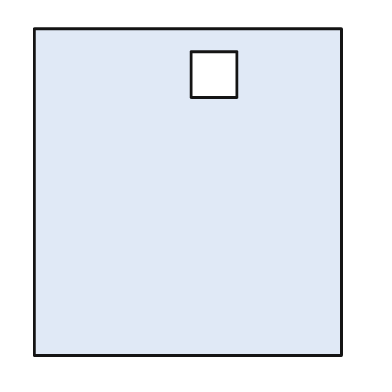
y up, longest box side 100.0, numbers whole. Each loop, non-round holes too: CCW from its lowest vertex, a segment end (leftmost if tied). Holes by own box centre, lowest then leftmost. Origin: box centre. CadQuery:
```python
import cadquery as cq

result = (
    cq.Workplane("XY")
    .moveTo(-47.0, -50.0)
    .lineTo(47.0, -50.0)
    .lineTo(47.0, 50.0)
    .lineTo(-47.0, 50.0)
    .close()
    .moveTo(1.0, 29.0)
    .lineTo(15.0, 29.0)
    .lineTo(15.0, 43.0)
    .lineTo(1.0, 43.0)
    .close()
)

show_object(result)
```